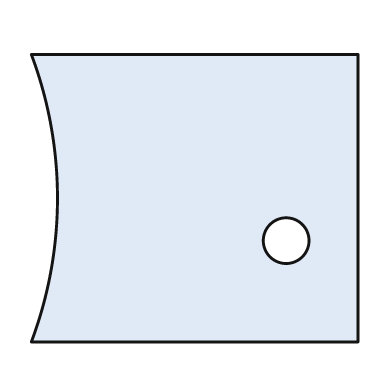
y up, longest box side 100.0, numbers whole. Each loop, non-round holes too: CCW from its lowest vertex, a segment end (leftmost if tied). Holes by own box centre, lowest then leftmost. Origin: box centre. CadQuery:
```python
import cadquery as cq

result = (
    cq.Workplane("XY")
    .moveTo(-50.0, -44.0)
    .lineTo(50.0, -44.0)
    .lineTo(50.0, 44.0)
    .lineTo(-50.0, 44.0)
    .threePointArc((-42.0, 0.0), (-50.0, -44.0))
    .close()
    .moveTo(28.0, -13.0)
    .circle(7.0)
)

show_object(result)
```